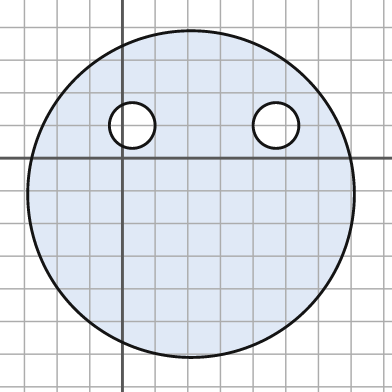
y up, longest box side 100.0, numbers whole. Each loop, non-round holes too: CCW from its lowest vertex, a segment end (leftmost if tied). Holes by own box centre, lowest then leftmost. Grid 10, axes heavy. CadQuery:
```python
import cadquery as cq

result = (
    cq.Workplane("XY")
    .moveTo(21.0, -11.0)
    .circle(50.0)
    .moveTo(3.0, 10.0)
    .circle(7.0)
    .moveTo(47.0, 10.0)
    .circle(7.0)
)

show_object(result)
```